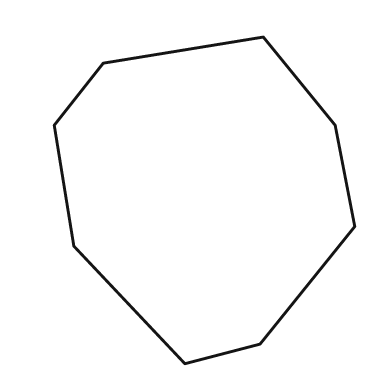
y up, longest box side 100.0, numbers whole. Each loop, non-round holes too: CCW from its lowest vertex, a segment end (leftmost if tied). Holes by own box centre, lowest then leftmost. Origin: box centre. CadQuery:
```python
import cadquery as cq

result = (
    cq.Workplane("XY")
    .moveTo(-6.0, -50.0)
    .lineTo(17.0, -44.0)
    .lineTo(46.0, -8.0)
    .lineTo(40.0, 23.0)
    .lineTo(18.0, 50.0)
    .lineTo(-31.0, 42.0)
    .lineTo(-46.0, 23.0)
    .lineTo(-40.0, -14.0)
    .close()
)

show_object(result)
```